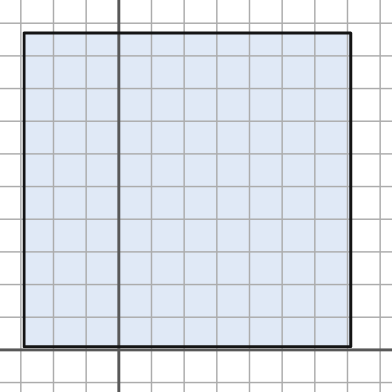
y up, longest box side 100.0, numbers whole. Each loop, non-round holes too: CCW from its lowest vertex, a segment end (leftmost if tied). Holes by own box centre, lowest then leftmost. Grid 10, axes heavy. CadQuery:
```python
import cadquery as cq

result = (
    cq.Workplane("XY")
    .moveTo(-29.0, 1.0)
    .lineTo(71.0, 1.0)
    .lineTo(71.0, 97.0)
    .lineTo(-29.0, 97.0)
    .close()
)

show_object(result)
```